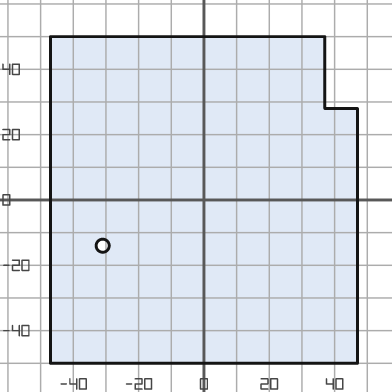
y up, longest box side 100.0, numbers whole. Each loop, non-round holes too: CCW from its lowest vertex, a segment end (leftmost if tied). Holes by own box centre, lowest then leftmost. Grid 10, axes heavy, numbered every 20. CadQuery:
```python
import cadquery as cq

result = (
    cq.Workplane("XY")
    .moveTo(-47.0, -50.0)
    .lineTo(47.0, -50.0)
    .lineTo(47.0, 28.0)
    .lineTo(37.0, 28.0)
    .lineTo(37.0, 50.0)
    .lineTo(-47.0, 50.0)
    .close()
    .moveTo(-31.0, -14.0)
    .circle(2.0)
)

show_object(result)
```